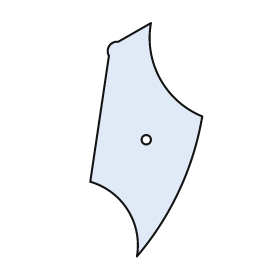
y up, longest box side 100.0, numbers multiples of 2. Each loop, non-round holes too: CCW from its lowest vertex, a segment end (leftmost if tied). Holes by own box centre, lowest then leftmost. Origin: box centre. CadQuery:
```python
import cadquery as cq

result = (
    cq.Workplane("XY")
    .moveTo(-4.0, -50.0)
    .threePointArc((14.0, -22.0), (24.0, 10.0))
    .threePointArc((6.0, 26.0), (2.0, 50.0))
    .lineTo(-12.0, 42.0)
    .threePointArc((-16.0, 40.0), (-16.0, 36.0))
    .lineTo(-24.0, -18.0)
    .threePointArc((-8.0, -30.0), (-4.0, -50.0))
    .close()
    .moveTo(0.0, 0.0)
    .circle(2.0)
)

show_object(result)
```